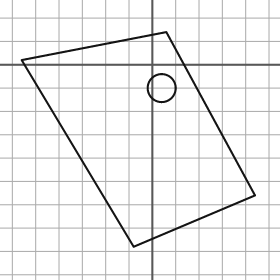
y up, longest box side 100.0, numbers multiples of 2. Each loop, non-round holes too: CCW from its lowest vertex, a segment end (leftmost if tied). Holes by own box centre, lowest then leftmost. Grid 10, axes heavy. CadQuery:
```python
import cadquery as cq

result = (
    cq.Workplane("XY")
    .moveTo(-8.0, -78.0)
    .lineTo(44.0, -56.0)
    .lineTo(6.0, 14.0)
    .lineTo(-56.0, 2.0)
    .close()
    .moveTo(4.0, -10.0)
    .circle(6.0)
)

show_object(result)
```